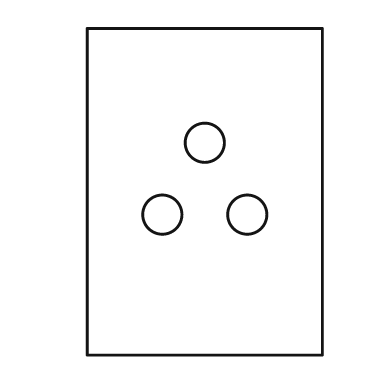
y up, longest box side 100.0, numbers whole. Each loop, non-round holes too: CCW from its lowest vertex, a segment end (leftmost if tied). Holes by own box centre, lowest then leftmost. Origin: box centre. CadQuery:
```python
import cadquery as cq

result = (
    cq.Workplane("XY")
    .moveTo(-36.0, -50.0)
    .lineTo(36.0, -50.0)
    .lineTo(36.0, 50.0)
    .lineTo(-36.0, 50.0)
    .close()
    .moveTo(-13.0, -7.0)
    .circle(6.0)
    .moveTo(13.0, -7.0)
    .circle(6.0)
    .moveTo(0.0, 15.0)
    .circle(6.0)
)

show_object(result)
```